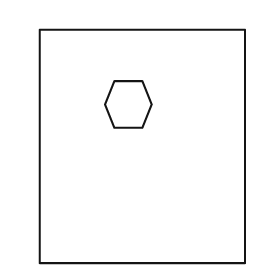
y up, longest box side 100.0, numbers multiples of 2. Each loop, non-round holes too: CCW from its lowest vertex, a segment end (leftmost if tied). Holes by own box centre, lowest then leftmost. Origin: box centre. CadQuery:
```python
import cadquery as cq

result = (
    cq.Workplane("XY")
    .moveTo(-44.0, -50.0)
    .lineTo(44.0, -50.0)
    .lineTo(44.0, 50.0)
    .lineTo(-44.0, 50.0)
    .close()
    .moveTo(-12.0, 8.0)
    .lineTo(0.0, 8.0)
    .lineTo(4.0, 18.0)
    .lineTo(0.0, 28.0)
    .lineTo(-12.0, 28.0)
    .lineTo(-16.0, 18.0)
    .close()
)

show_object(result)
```